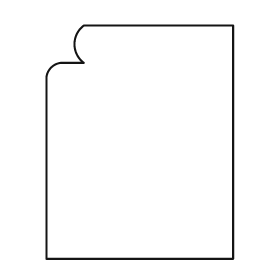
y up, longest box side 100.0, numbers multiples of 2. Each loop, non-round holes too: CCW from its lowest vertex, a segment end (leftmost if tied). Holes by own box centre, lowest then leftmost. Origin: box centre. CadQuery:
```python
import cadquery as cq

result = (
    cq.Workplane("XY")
    .moveTo(-40.0, -50.0)
    .lineTo(40.0, -50.0)
    .lineTo(40.0, 50.0)
    .lineTo(-24.0, 50.0)
    .threePointArc((-28.0, 42.0), (-24.0, 34.0))
    .lineTo(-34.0, 34.0)
    .threePointArc((-38.0, 32.0), (-40.0, 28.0))
    .close()
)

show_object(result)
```